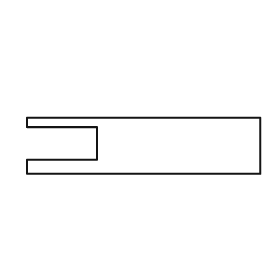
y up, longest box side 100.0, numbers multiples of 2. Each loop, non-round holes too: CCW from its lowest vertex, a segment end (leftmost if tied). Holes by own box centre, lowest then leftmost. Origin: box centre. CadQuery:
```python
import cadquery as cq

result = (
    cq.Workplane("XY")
    .moveTo(-50.0, -12.0)
    .lineTo(50.0, -12.0)
    .lineTo(50.0, 12.0)
    .lineTo(-50.0, 12.0)
    .lineTo(-50.0, 8.0)
    .lineTo(-20.0, 8.0)
    .lineTo(-20.0, -6.0)
    .lineTo(-50.0, -6.0)
    .close()
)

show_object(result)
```